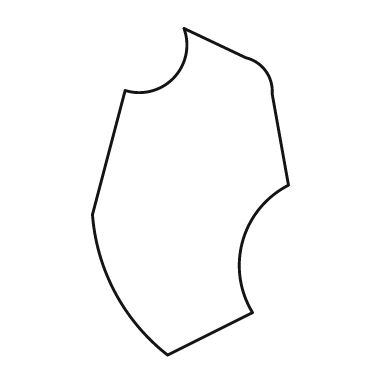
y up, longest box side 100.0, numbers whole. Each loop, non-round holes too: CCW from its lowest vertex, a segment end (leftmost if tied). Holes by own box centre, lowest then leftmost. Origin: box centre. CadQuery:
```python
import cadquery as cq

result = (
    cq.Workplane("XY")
    .moveTo(-7.0, -50.0)
    .lineTo(19.0, -37.0)
    .threePointArc((16.0, -15.0), (30.0, 2.0))
    .lineTo(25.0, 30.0)
    .threePointArc((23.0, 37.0), (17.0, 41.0))
    .lineTo(-2.0, 50.0)
    .threePointArc((-5.0, 35.0), (-20.0, 31.0))
    .lineTo(-30.0, -7.0)
    .threePointArc((-23.0, -31.0), (-7.0, -50.0))
    .close()
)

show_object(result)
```